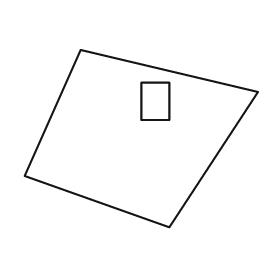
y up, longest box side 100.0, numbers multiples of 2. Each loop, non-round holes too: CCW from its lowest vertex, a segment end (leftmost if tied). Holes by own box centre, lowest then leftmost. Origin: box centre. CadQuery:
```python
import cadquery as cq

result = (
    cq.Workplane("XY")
    .moveTo(12.0, -38.0)
    .lineTo(50.0, 20.0)
    .lineTo(-26.0, 38.0)
    .lineTo(-50.0, -16.0)
    .close()
    .moveTo(0.0, 8.0)
    .lineTo(12.0, 8.0)
    .lineTo(12.0, 24.0)
    .lineTo(0.0, 24.0)
    .close()
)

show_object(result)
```